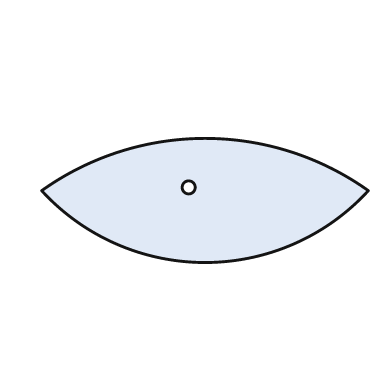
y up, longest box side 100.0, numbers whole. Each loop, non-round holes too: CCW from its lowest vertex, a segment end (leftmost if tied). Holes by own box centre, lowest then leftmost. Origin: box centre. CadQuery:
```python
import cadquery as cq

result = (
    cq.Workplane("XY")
    .moveTo(-50.0, 3.0)
    .threePointArc((0.0, -19.0), (50.0, 3.0))
    .threePointArc((0.0, 19.0), (-50.0, 3.0))
    .close()
    .moveTo(-5.0, 4.0)
    .circle(2.0)
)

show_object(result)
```